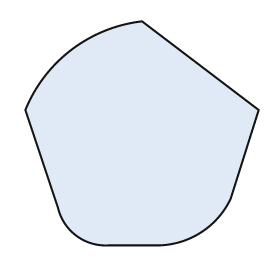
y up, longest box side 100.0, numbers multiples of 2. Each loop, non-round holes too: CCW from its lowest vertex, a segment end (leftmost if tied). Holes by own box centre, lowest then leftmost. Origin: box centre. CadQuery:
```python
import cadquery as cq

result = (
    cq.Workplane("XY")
    .moveTo(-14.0, -48.0)
    .lineTo(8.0, -48.0)
    .threePointArc((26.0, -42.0), (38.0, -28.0))
    .lineTo(50.0, 10.0)
    .lineTo(0.0, 48.0)
    .threePointArc((-30.0, 36.0), (-50.0, 10.0))
    .lineTo(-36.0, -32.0)
    .threePointArc((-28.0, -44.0), (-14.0, -48.0))
    .close()
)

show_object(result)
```